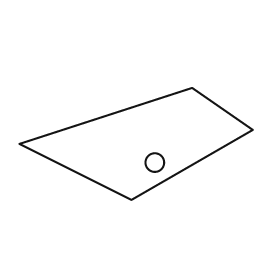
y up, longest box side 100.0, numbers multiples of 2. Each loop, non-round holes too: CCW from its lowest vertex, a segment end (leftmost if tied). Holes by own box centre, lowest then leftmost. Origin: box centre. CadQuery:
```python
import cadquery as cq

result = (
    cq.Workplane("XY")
    .moveTo(-2.0, -24.0)
    .lineTo(50.0, 6.0)
    .lineTo(24.0, 24.0)
    .lineTo(-50.0, 0.0)
    .close()
    .moveTo(8.0, -8.0)
    .circle(4.0)
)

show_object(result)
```